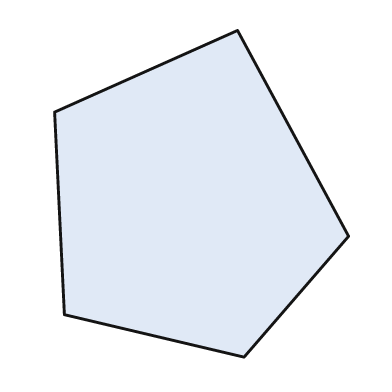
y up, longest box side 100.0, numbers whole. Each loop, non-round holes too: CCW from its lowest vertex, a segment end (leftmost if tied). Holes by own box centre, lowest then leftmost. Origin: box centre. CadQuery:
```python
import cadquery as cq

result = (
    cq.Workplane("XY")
    .moveTo(13.0, -50.0)
    .lineTo(45.0, -13.0)
    .lineTo(11.0, 50.0)
    .lineTo(-45.0, 25.0)
    .lineTo(-42.0, -37.0)
    .close()
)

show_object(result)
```